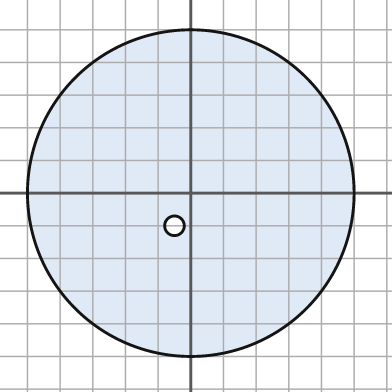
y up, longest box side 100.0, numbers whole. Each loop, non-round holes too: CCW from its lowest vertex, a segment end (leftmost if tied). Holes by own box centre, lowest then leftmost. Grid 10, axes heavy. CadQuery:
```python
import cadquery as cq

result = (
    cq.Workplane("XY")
    .moveTo(0.0, 0.0)
    .circle(50.0)
    .moveTo(-5.0, -10.0)
    .circle(3.0)
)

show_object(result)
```